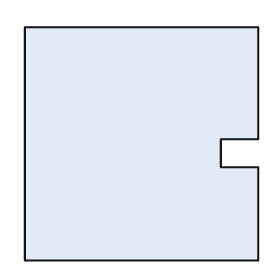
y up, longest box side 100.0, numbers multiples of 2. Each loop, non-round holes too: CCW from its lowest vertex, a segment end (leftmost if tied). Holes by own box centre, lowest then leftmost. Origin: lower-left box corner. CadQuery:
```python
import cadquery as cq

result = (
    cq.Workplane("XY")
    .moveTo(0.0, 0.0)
    .lineTo(100.0, 0.0)
    .lineTo(100.0, 40.0)
    .lineTo(84.0, 40.0)
    .lineTo(84.0, 52.0)
    .lineTo(100.0, 52.0)
    .lineTo(100.0, 100.0)
    .lineTo(0.0, 100.0)
    .close()
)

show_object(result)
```